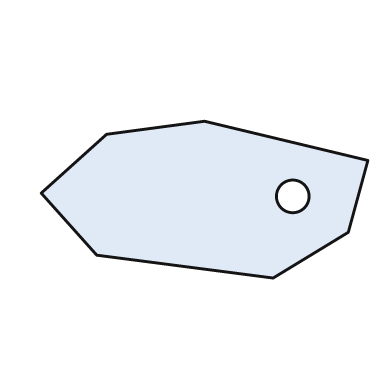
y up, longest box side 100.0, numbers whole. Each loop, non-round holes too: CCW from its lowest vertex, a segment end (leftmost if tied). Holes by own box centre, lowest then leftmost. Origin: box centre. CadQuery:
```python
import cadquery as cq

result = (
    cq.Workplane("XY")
    .moveTo(21.0, -24.0)
    .lineTo(44.0, -10.0)
    .lineTo(50.0, 12.0)
    .lineTo(0.0, 24.0)
    .lineTo(-30.0, 20.0)
    .lineTo(-50.0, 2.0)
    .lineTo(-33.0, -17.0)
    .close()
    .moveTo(27.0, 1.0)
    .circle(5.0)
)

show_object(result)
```